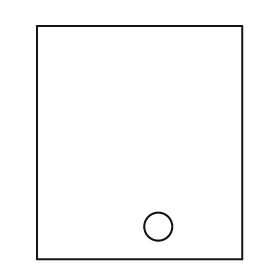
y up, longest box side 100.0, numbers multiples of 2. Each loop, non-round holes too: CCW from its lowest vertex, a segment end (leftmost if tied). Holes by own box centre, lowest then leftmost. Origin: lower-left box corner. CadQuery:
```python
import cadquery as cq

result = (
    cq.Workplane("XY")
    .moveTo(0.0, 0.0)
    .lineTo(88.0, 0.0)
    .lineTo(88.0, 100.0)
    .lineTo(0.0, 100.0)
    .close()
    .moveTo(52.0, 14.0)
    .circle(6.0)
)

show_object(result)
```